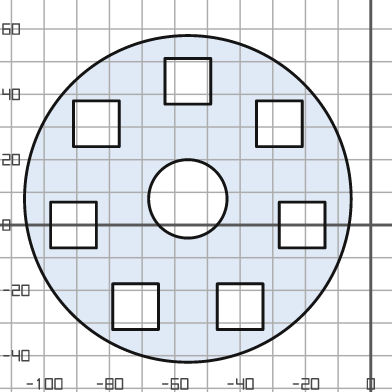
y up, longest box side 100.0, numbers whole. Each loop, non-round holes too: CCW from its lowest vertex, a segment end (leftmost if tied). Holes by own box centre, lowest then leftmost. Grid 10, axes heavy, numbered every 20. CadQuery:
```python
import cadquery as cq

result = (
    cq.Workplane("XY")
    .moveTo(-56.0, 8.0)
    .circle(50.0)
    .moveTo(-79.0, -32.0)
    .lineTo(-65.0, -32.0)
    .lineTo(-65.0, -18.0)
    .lineTo(-79.0, -18.0)
    .close()
    .moveTo(-47.0, -32.0)
    .lineTo(-33.0, -32.0)
    .lineTo(-33.0, -18.0)
    .lineTo(-47.0, -18.0)
    .close()
    .moveTo(-98.0, -7.0)
    .lineTo(-84.0, -7.0)
    .lineTo(-84.0, 7.0)
    .lineTo(-98.0, 7.0)
    .close()
    .moveTo(-28.0, -7.0)
    .lineTo(-14.0, -7.0)
    .lineTo(-14.0, 7.0)
    .lineTo(-28.0, 7.0)
    .close()
    .moveTo(-56.0, 8.0)
    .circle(12.0)
    .moveTo(-91.0, 24.0)
    .lineTo(-77.0, 24.0)
    .lineTo(-77.0, 38.0)
    .lineTo(-91.0, 38.0)
    .close()
    .moveTo(-35.0, 24.0)
    .lineTo(-21.0, 24.0)
    .lineTo(-21.0, 38.0)
    .lineTo(-35.0, 38.0)
    .close()
    .moveTo(-63.0, 37.0)
    .lineTo(-49.0, 37.0)
    .lineTo(-49.0, 51.0)
    .lineTo(-63.0, 51.0)
    .close()
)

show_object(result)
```